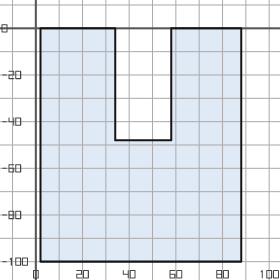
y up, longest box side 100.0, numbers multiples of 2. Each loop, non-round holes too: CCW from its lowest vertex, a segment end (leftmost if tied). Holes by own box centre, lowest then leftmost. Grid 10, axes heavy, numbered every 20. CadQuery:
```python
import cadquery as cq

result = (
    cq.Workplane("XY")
    .moveTo(2.0, -100.0)
    .lineTo(88.0, -100.0)
    .lineTo(88.0, 0.0)
    .lineTo(58.0, 0.0)
    .lineTo(58.0, -48.0)
    .lineTo(34.0, -48.0)
    .lineTo(34.0, 0.0)
    .lineTo(2.0, 0.0)
    .close()
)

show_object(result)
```